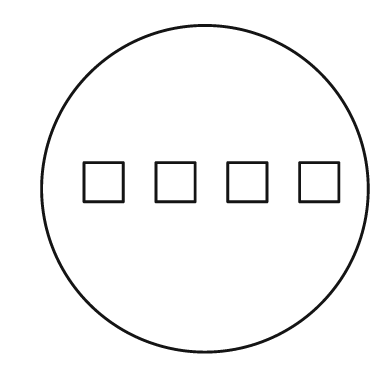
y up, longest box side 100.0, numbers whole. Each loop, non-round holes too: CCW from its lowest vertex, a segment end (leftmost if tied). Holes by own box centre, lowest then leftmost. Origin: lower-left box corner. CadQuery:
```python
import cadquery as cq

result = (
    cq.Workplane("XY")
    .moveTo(50.0, 50.0)
    .circle(50.0)
    .moveTo(13.0, 46.0)
    .lineTo(25.0, 46.0)
    .lineTo(25.0, 58.0)
    .lineTo(13.0, 58.0)
    .close()
    .moveTo(35.0, 46.0)
    .lineTo(47.0, 46.0)
    .lineTo(47.0, 58.0)
    .lineTo(35.0, 58.0)
    .close()
    .moveTo(57.0, 46.0)
    .lineTo(69.0, 46.0)
    .lineTo(69.0, 58.0)
    .lineTo(57.0, 58.0)
    .close()
    .moveTo(79.0, 46.0)
    .lineTo(91.0, 46.0)
    .lineTo(91.0, 58.0)
    .lineTo(79.0, 58.0)
    .close()
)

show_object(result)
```